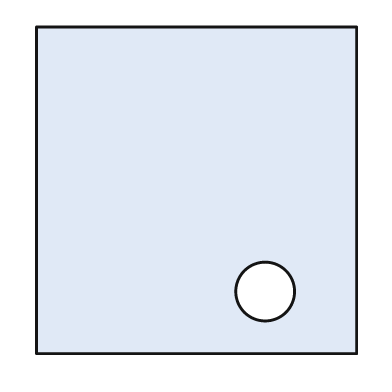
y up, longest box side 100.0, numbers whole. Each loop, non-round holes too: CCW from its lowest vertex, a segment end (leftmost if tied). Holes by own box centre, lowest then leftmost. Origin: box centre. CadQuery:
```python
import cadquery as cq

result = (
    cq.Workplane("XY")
    .moveTo(-49.0, -50.0)
    .lineTo(49.0, -50.0)
    .lineTo(49.0, 50.0)
    .lineTo(-49.0, 50.0)
    .close()
    .moveTo(21.0, -31.0)
    .circle(9.0)
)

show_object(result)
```